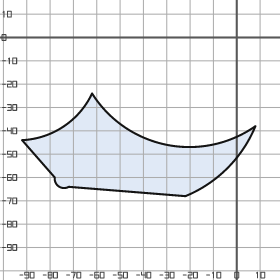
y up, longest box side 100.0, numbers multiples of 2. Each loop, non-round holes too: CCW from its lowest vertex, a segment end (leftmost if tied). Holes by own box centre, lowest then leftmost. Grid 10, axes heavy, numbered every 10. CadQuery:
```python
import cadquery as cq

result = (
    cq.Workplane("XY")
    .moveTo(-22.0, -68.0)
    .threePointArc((-4.0, -56.0), (8.0, -38.0))
    .threePointArc((-30.0, -46.0), (-62.0, -24.0))
    .threePointArc((-74.0, -38.0), (-92.0, -44.0))
    .lineTo(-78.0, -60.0)
    .threePointArc((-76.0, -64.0), (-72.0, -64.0))
    .close()
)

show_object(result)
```